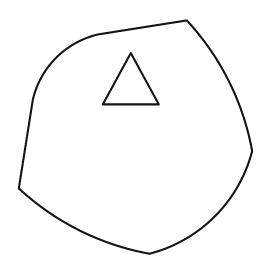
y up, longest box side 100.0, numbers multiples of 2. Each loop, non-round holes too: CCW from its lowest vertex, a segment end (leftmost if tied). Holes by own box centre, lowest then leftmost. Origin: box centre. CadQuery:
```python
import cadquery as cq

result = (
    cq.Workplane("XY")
    .moveTo(6.0, -50.0)
    .threePointArc((34.0, -34.0), (50.0, -6.0))
    .threePointArc((40.0, 24.0), (22.0, 50.0))
    .lineTo(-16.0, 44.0)
    .threePointArc((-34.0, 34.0), (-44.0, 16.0))
    .lineTo(-50.0, -22.0)
    .threePointArc((-24.0, -40.0), (6.0, -50.0))
    .close()
    .moveTo(-14.0, 14.0)
    .lineTo(10.0, 14.0)
    .lineTo(-2.0, 36.0)
    .close()
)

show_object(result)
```